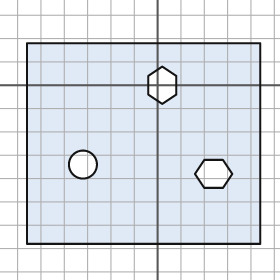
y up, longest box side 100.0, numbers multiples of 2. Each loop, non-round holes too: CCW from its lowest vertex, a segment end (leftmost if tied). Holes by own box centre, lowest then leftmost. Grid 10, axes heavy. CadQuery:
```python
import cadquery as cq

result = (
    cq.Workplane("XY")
    .moveTo(-56.0, -68.0)
    .lineTo(44.0, -68.0)
    .lineTo(44.0, 18.0)
    .lineTo(-56.0, 18.0)
    .close()
    .moveTo(20.0, -44.0)
    .lineTo(28.0, -44.0)
    .lineTo(32.0, -38.0)
    .lineTo(28.0, -32.0)
    .lineTo(20.0, -32.0)
    .lineTo(16.0, -38.0)
    .close()
    .moveTo(-32.0, -34.0)
    .circle(6.0)
    .moveTo(2.0, -8.0)
    .lineTo(8.0, -4.0)
    .lineTo(8.0, 4.0)
    .lineTo(2.0, 8.0)
    .lineTo(-4.0, 4.0)
    .lineTo(-4.0, -4.0)
    .close()
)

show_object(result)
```